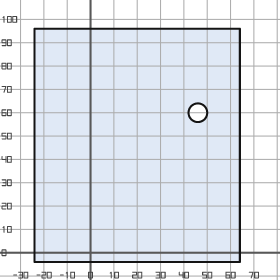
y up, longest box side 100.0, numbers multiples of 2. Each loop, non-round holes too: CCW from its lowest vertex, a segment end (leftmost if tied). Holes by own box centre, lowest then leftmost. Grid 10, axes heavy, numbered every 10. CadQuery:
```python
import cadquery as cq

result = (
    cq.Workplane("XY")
    .moveTo(-24.0, -4.0)
    .lineTo(64.0, -4.0)
    .lineTo(64.0, 96.0)
    .lineTo(-24.0, 96.0)
    .close()
    .moveTo(46.0, 60.0)
    .circle(4.0)
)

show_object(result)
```